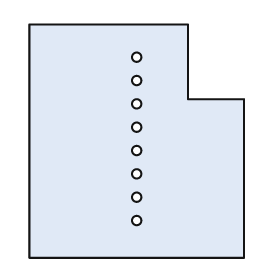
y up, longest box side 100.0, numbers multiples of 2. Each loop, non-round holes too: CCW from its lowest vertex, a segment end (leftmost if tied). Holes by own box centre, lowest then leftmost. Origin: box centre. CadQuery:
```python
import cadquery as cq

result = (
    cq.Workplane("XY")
    .moveTo(-46.0, -50.0)
    .lineTo(46.0, -50.0)
    .lineTo(46.0, 18.0)
    .lineTo(22.0, 18.0)
    .lineTo(22.0, 50.0)
    .lineTo(-46.0, 50.0)
    .close()
    .moveTo(0.0, -34.0)
    .circle(2.0)
    .moveTo(0.0, -24.0)
    .circle(2.0)
    .moveTo(0.0, -14.0)
    .circle(2.0)
    .moveTo(0.0, -4.0)
    .circle(2.0)
    .moveTo(0.0, 6.0)
    .circle(2.0)
    .moveTo(0.0, 16.0)
    .circle(2.0)
    .moveTo(0.0, 26.0)
    .circle(2.0)
    .moveTo(0.0, 36.0)
    .circle(2.0)
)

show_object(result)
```